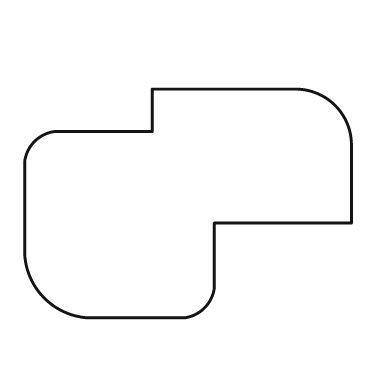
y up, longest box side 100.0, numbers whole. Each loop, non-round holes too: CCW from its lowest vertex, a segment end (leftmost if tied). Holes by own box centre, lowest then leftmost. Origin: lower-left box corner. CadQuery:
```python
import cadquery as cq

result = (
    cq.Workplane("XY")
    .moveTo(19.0, 0.0)
    .lineTo(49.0, 0.0)
    .threePointArc((55.0, 3.0), (58.0, 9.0))
    .lineTo(58.0, 29.0)
    .lineTo(100.0, 29.0)
    .lineTo(100.0, 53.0)
    .threePointArc((95.0, 65.0), (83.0, 70.0))
    .lineTo(39.0, 70.0)
    .lineTo(39.0, 57.0)
    .lineTo(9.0, 57.0)
    .threePointArc((3.0, 54.0), (0.0, 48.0))
    .lineTo(0.0, 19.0)
    .threePointArc((6.0, 6.0), (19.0, 0.0))
    .close()
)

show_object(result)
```